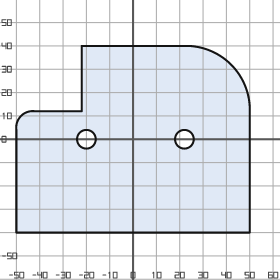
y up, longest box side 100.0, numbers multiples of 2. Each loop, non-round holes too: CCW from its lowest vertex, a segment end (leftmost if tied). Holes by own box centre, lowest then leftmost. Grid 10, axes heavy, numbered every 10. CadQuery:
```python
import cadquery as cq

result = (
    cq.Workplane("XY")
    .moveTo(-50.0, -40.0)
    .lineTo(50.0, -40.0)
    .lineTo(50.0, 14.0)
    .threePointArc((42.0, 32.0), (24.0, 40.0))
    .lineTo(-22.0, 40.0)
    .lineTo(-22.0, 12.0)
    .lineTo(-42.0, 12.0)
    .threePointArc((-48.0, 10.0), (-50.0, 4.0))
    .close()
    .moveTo(-20.0, 0.0)
    .circle(4.0)
    .moveTo(22.0, 0.0)
    .circle(4.0)
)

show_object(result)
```